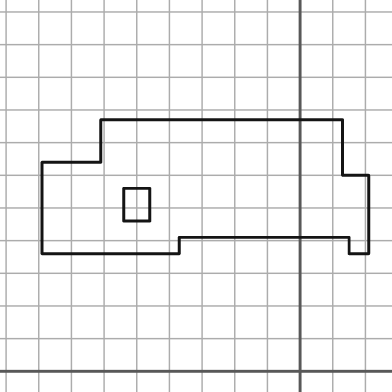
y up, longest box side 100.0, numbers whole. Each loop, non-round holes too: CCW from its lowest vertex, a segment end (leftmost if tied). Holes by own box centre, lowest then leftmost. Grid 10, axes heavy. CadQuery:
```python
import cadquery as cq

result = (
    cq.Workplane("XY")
    .moveTo(-79.0, 36.0)
    .lineTo(-37.0, 36.0)
    .lineTo(-37.0, 41.0)
    .lineTo(15.0, 41.0)
    .lineTo(15.0, 36.0)
    .lineTo(21.0, 36.0)
    .lineTo(21.0, 60.0)
    .lineTo(13.0, 60.0)
    .lineTo(13.0, 77.0)
    .lineTo(-61.0, 77.0)
    .lineTo(-61.0, 64.0)
    .lineTo(-79.0, 64.0)
    .close()
    .moveTo(-54.0, 46.0)
    .lineTo(-46.0, 46.0)
    .lineTo(-46.0, 56.0)
    .lineTo(-54.0, 56.0)
    .close()
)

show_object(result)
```